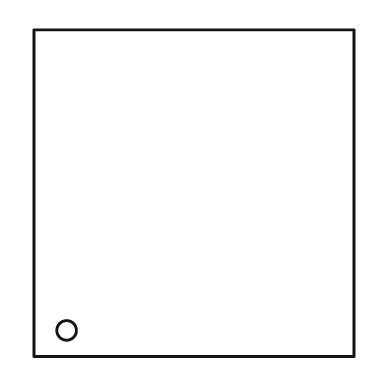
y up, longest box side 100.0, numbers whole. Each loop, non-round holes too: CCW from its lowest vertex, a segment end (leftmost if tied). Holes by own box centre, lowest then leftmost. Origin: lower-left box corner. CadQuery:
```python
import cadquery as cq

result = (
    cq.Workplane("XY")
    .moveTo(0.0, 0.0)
    .lineTo(98.0, 0.0)
    .lineTo(98.0, 100.0)
    .lineTo(0.0, 100.0)
    .close()
    .moveTo(10.0, 8.0)
    .circle(3.0)
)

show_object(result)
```